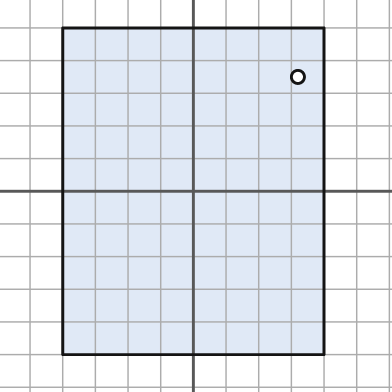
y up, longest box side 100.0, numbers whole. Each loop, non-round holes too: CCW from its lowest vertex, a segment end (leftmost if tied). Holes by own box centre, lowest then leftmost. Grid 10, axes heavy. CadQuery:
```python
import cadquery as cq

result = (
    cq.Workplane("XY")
    .moveTo(-40.0, -50.0)
    .lineTo(40.0, -50.0)
    .lineTo(40.0, 50.0)
    .lineTo(-40.0, 50.0)
    .close()
    .moveTo(32.0, 35.0)
    .circle(2.0)
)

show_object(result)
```